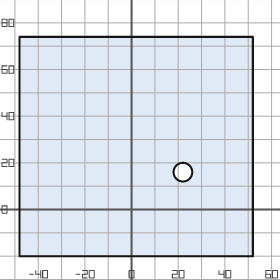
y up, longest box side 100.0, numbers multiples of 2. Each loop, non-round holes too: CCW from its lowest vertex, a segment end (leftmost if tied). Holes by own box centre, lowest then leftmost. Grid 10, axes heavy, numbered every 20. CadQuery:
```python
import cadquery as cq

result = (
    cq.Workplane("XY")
    .moveTo(-48.0, -20.0)
    .lineTo(52.0, -20.0)
    .lineTo(52.0, 74.0)
    .lineTo(-48.0, 74.0)
    .close()
    .moveTo(22.0, 16.0)
    .circle(4.0)
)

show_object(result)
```